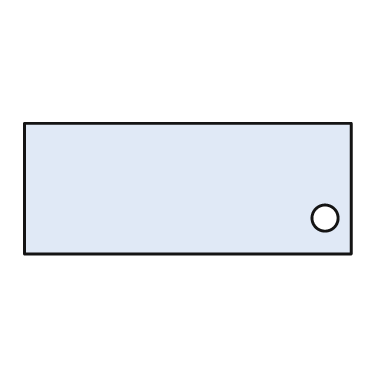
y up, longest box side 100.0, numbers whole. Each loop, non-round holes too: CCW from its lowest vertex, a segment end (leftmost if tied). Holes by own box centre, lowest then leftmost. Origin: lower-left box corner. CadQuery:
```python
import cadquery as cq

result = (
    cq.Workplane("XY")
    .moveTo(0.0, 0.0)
    .lineTo(100.0, 0.0)
    .lineTo(100.0, 40.0)
    .lineTo(0.0, 40.0)
    .close()
    .moveTo(92.0, 11.0)
    .circle(4.0)
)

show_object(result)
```